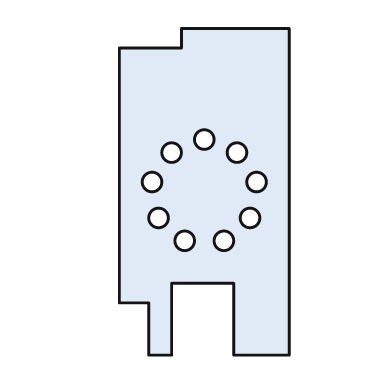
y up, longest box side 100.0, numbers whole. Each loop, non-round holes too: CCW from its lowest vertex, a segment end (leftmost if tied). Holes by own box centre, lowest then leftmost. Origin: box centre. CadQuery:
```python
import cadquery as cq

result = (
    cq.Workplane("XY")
    .moveTo(-17.0, -50.0)
    .lineTo(-10.0, -50.0)
    .lineTo(-10.0, -28.0)
    .lineTo(9.0, -28.0)
    .lineTo(9.0, -50.0)
    .lineTo(26.0, -50.0)
    .lineTo(26.0, 50.0)
    .lineTo(-7.0, 50.0)
    .lineTo(-7.0, 44.0)
    .lineTo(-26.0, 44.0)
    .lineTo(-26.0, -34.0)
    .lineTo(-17.0, -34.0)
    .close()
    .moveTo(-6.0, -15.0)
    .circle(3.0)
    .moveTo(6.0, -15.0)
    .circle(3.0)
    .moveTo(-14.0, -8.0)
    .circle(3.0)
    .moveTo(14.0, -8.0)
    .circle(3.0)
    .moveTo(-16.0, 3.0)
    .circle(3.0)
    .moveTo(16.0, 3.0)
    .circle(3.0)
    .moveTo(-10.0, 12.0)
    .circle(3.0)
    .moveTo(10.0, 12.0)
    .circle(3.0)
    .moveTo(0.0, 16.0)
    .circle(3.0)
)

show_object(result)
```